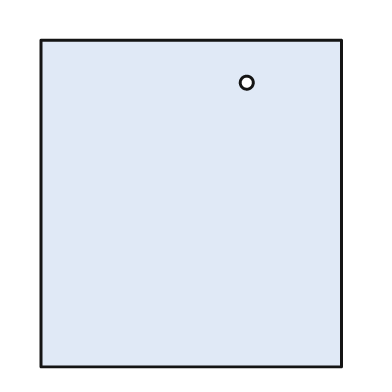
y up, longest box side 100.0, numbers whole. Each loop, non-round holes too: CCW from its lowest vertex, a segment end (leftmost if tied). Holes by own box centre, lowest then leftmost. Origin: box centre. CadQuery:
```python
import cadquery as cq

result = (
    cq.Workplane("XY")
    .moveTo(-46.0, -50.0)
    .lineTo(46.0, -50.0)
    .lineTo(46.0, 50.0)
    .lineTo(-46.0, 50.0)
    .close()
    .moveTo(17.0, 37.0)
    .circle(2.0)
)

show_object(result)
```